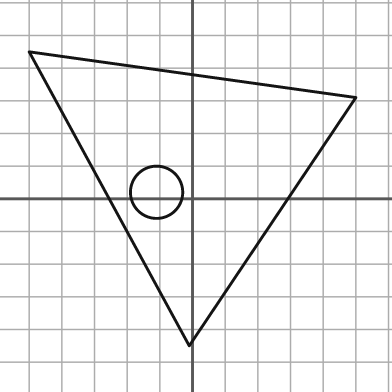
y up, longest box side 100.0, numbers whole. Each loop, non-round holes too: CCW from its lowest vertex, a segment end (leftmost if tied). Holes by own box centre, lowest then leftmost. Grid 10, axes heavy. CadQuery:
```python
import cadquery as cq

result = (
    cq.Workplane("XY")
    .moveTo(-1.0, -45.0)
    .lineTo(50.0, 31.0)
    .lineTo(-50.0, 45.0)
    .close()
    .moveTo(-11.0, 2.0)
    .circle(8.0)
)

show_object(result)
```